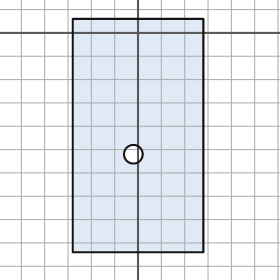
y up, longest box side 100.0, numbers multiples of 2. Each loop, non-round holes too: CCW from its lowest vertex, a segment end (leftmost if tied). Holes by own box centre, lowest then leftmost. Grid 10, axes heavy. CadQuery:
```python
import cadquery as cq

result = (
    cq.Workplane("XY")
    .moveTo(-28.0, -94.0)
    .lineTo(28.0, -94.0)
    .lineTo(28.0, 6.0)
    .lineTo(-28.0, 6.0)
    .close()
    .moveTo(-2.0, -52.0)
    .circle(4.0)
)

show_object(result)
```